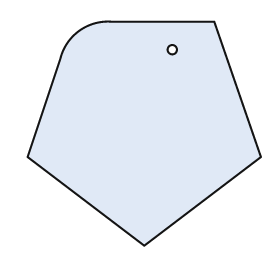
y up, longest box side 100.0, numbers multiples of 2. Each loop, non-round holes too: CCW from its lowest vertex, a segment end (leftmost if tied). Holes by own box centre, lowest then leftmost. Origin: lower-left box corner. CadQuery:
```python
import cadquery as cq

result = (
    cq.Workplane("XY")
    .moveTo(50.0, 0.0)
    .lineTo(100.0, 38.0)
    .lineTo(80.0, 96.0)
    .lineTo(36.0, 96.0)
    .threePointArc((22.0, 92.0), (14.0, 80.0))
    .lineTo(0.0, 38.0)
    .close()
    .moveTo(62.0, 84.0)
    .circle(2.0)
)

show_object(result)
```